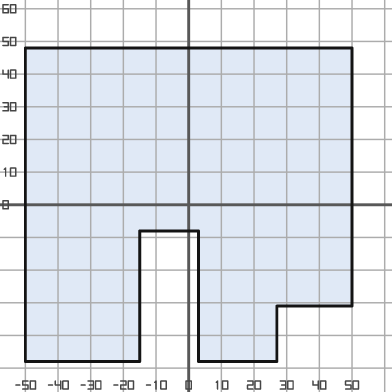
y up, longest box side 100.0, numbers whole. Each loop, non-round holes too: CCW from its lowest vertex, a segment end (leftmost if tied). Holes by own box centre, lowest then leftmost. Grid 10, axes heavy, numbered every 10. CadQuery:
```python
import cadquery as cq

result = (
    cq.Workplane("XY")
    .moveTo(-50.0, -48.0)
    .lineTo(-15.0, -48.0)
    .lineTo(-15.0, -8.0)
    .lineTo(3.0, -8.0)
    .lineTo(3.0, -48.0)
    .lineTo(27.0, -48.0)
    .lineTo(27.0, -31.0)
    .lineTo(50.0, -31.0)
    .lineTo(50.0, 48.0)
    .lineTo(-50.0, 48.0)
    .close()
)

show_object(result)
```